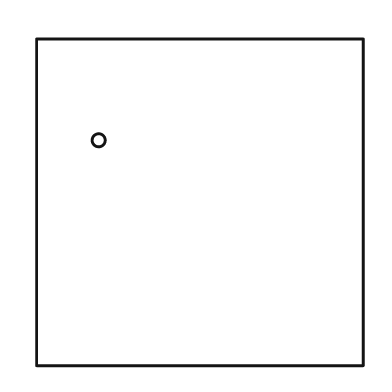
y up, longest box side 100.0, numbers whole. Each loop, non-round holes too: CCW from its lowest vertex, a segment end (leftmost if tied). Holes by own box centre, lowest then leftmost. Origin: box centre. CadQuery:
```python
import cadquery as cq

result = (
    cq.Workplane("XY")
    .moveTo(-50.0, -50.0)
    .lineTo(50.0, -50.0)
    .lineTo(50.0, 50.0)
    .lineTo(-50.0, 50.0)
    .close()
    .moveTo(-31.0, 19.0)
    .circle(2.0)
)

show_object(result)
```